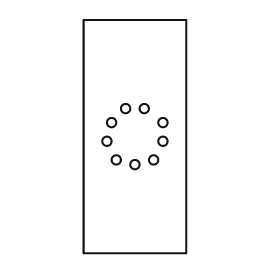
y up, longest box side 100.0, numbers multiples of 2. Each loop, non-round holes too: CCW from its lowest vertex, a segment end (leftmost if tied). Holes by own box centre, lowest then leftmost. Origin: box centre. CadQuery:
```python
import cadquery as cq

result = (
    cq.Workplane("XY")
    .moveTo(-22.0, -50.0)
    .lineTo(22.0, -50.0)
    .lineTo(22.0, 50.0)
    .lineTo(-22.0, 50.0)
    .close()
    .moveTo(0.0, -12.0)
    .circle(2.0)
    .moveTo(-8.0, -10.0)
    .circle(2.0)
    .moveTo(8.0, -10.0)
    .circle(2.0)
    .moveTo(-12.0, -2.0)
    .circle(2.0)
    .moveTo(12.0, -2.0)
    .circle(2.0)
    .moveTo(-10.0, 6.0)
    .circle(2.0)
    .moveTo(12.0, 6.0)
    .circle(2.0)
    .moveTo(-4.0, 12.0)
    .circle(2.0)
    .moveTo(4.0, 12.0)
    .circle(2.0)
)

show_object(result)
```